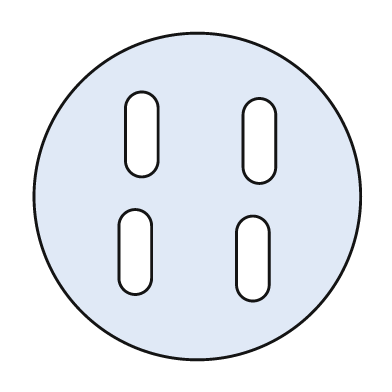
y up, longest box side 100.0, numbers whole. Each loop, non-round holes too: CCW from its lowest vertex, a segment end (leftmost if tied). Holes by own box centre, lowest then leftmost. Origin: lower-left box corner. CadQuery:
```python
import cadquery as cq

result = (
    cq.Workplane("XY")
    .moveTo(50.0, 50.0)
    .circle(50.0)
    .moveTo(62.0, 23.0)
    .threePointArc((67.0, 18.0), (72.0, 23.0))
    .lineTo(72.0, 39.0)
    .threePointArc((67.0, 44.0), (62.0, 39.0))
    .close()
    .moveTo(26.0, 25.0)
    .threePointArc((31.0, 20.0), (36.0, 25.0))
    .lineTo(36.0, 41.0)
    .threePointArc((31.0, 46.0), (26.0, 41.0))
    .close()
    .moveTo(64.0, 59.0)
    .threePointArc((69.0, 54.0), (74.0, 59.0))
    .lineTo(74.0, 75.0)
    .threePointArc((69.0, 80.0), (64.0, 75.0))
    .close()
    .moveTo(28.0, 61.0)
    .threePointArc((33.0, 56.0), (38.0, 61.0))
    .lineTo(38.0, 77.0)
    .threePointArc((33.0, 82.0), (28.0, 77.0))
    .close()
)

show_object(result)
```